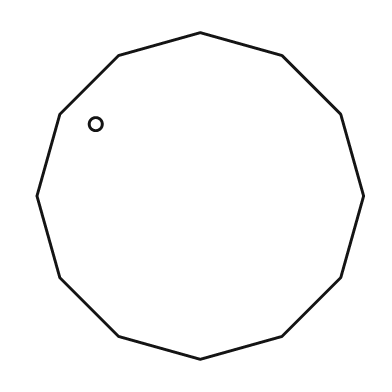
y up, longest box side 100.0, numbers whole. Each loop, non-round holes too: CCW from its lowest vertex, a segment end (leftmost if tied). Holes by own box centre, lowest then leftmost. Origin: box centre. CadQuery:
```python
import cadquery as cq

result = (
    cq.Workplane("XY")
    .moveTo(0.0, -50.0)
    .lineTo(25.0, -43.0)
    .lineTo(43.0, -25.0)
    .lineTo(50.0, 0.0)
    .lineTo(43.0, 25.0)
    .lineTo(25.0, 43.0)
    .lineTo(0.0, 50.0)
    .lineTo(-25.0, 43.0)
    .lineTo(-43.0, 25.0)
    .lineTo(-50.0, 0.0)
    .lineTo(-43.0, -25.0)
    .lineTo(-25.0, -43.0)
    .close()
    .moveTo(-32.0, 22.0)
    .circle(2.0)
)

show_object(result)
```